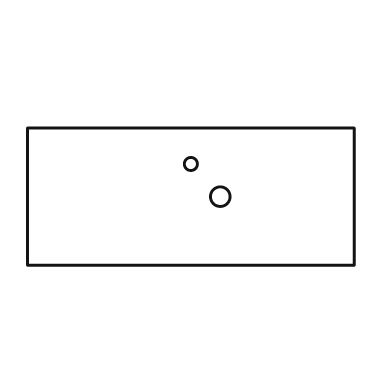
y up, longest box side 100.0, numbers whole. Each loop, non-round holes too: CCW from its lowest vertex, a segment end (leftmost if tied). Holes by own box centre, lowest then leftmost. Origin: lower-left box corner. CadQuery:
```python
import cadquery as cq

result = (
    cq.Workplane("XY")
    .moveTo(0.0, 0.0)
    .lineTo(100.0, 0.0)
    .lineTo(100.0, 42.0)
    .lineTo(0.0, 42.0)
    .close()
    .moveTo(59.0, 21.0)
    .circle(3.0)
    .moveTo(50.0, 31.0)
    .circle(2.0)
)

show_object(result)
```